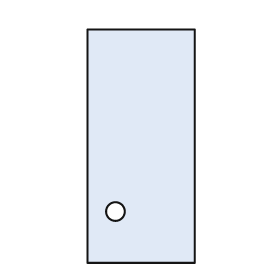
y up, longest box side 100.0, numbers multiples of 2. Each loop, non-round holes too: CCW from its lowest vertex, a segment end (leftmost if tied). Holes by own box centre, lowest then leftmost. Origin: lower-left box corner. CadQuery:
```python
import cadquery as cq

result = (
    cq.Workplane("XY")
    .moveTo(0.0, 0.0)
    .lineTo(46.0, 0.0)
    .lineTo(46.0, 100.0)
    .lineTo(0.0, 100.0)
    .close()
    .moveTo(12.0, 22.0)
    .circle(4.0)
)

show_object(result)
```